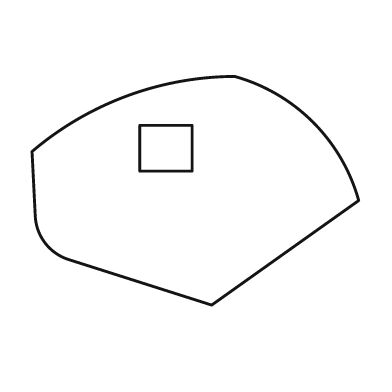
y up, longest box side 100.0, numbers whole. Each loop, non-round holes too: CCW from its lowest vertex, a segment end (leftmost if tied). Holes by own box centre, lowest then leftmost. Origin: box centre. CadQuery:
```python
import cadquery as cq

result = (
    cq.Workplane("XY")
    .moveTo(5.0, -35.0)
    .lineTo(50.0, -3.0)
    .threePointArc((36.0, 21.0), (12.0, 35.0))
    .threePointArc((-21.0, 29.0), (-50.0, 12.0))
    .lineTo(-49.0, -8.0)
    .threePointArc((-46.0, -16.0), (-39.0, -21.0))
    .close()
    .moveTo(-17.0, 6.0)
    .lineTo(-1.0, 6.0)
    .lineTo(-1.0, 20.0)
    .lineTo(-17.0, 20.0)
    .close()
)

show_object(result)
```